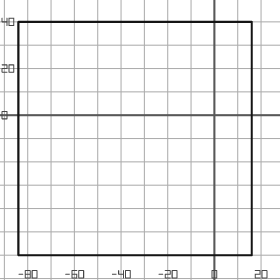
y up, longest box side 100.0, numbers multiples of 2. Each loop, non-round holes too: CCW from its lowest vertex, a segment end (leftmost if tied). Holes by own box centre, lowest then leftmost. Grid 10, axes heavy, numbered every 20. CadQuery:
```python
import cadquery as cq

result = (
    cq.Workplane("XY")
    .moveTo(-84.0, -60.0)
    .lineTo(16.0, -60.0)
    .lineTo(16.0, 40.0)
    .lineTo(-84.0, 40.0)
    .close()
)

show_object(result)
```